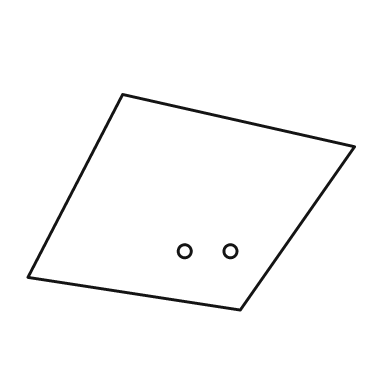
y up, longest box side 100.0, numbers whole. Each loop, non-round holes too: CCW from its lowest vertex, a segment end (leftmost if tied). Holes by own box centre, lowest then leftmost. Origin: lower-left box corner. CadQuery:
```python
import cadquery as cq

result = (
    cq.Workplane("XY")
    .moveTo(65.0, 0.0)
    .lineTo(100.0, 50.0)
    .lineTo(29.0, 66.0)
    .lineTo(0.0, 10.0)
    .close()
    .moveTo(48.0, 18.0)
    .circle(2.0)
    .moveTo(62.0, 18.0)
    .circle(2.0)
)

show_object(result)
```